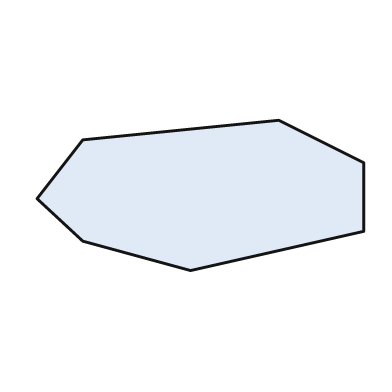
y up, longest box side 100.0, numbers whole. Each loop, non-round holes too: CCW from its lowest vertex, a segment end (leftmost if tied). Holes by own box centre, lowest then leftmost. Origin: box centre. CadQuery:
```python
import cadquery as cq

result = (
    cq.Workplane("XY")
    .moveTo(-3.0, -23.0)
    .lineTo(50.0, -11.0)
    .lineTo(50.0, 10.0)
    .lineTo(24.0, 23.0)
    .lineTo(-36.0, 17.0)
    .lineTo(-50.0, -1.0)
    .lineTo(-36.0, -14.0)
    .close()
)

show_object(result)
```